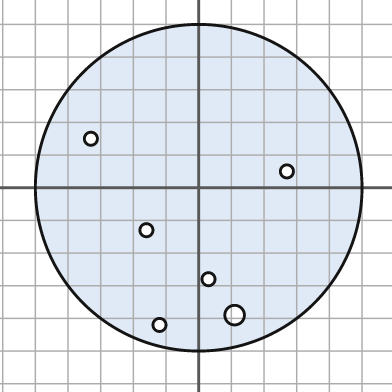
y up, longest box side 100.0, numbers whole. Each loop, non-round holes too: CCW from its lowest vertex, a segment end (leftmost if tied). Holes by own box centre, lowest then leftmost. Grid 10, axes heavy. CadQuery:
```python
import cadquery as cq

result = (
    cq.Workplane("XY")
    .moveTo(0.0, 0.0)
    .circle(50.0)
    .moveTo(-12.0, -42.0)
    .circle(2.0)
    .moveTo(11.0, -39.0)
    .circle(3.0)
    .moveTo(3.0, -28.0)
    .circle(2.0)
    .moveTo(-16.0, -13.0)
    .circle(2.0)
    .moveTo(27.0, 5.0)
    .circle(2.0)
    .moveTo(-33.0, 15.0)
    .circle(2.0)
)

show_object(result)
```